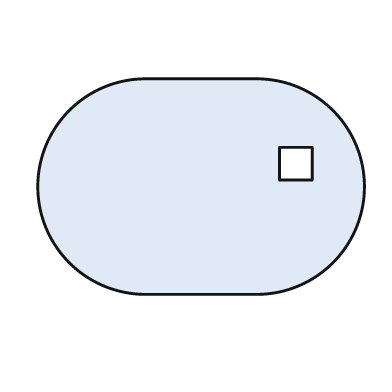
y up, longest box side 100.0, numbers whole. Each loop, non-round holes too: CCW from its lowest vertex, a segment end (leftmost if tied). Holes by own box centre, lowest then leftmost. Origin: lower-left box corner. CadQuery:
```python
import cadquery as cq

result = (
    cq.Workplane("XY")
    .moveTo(33.0, 0.0)
    .lineTo(67.0, 0.0)
    .threePointArc((100.0, 33.0), (67.0, 66.0))
    .lineTo(33.0, 66.0)
    .threePointArc((0.0, 33.0), (33.0, 0.0))
    .close()
    .moveTo(74.0, 35.0)
    .lineTo(84.0, 35.0)
    .lineTo(84.0, 45.0)
    .lineTo(74.0, 45.0)
    .close()
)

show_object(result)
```